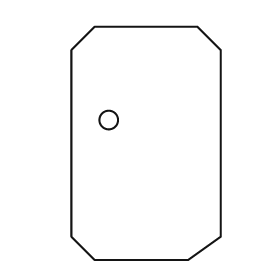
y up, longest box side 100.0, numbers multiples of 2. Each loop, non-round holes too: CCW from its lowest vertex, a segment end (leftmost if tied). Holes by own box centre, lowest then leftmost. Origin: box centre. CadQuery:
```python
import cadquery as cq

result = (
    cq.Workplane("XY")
    .moveTo(-22.0, -50.0)
    .lineTo(18.0, -50.0)
    .lineTo(32.0, -40.0)
    .lineTo(32.0, 40.0)
    .lineTo(22.0, 50.0)
    .lineTo(-22.0, 50.0)
    .lineTo(-32.0, 40.0)
    .lineTo(-32.0, -40.0)
    .close()
    .moveTo(-16.0, 10.0)
    .circle(4.0)
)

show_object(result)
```